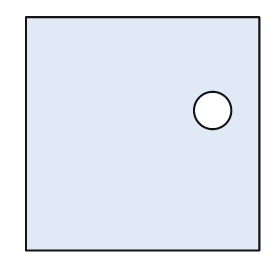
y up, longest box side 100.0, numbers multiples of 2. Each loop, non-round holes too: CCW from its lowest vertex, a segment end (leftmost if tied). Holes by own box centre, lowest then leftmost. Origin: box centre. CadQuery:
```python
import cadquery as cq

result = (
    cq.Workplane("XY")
    .moveTo(-50.0, -50.0)
    .lineTo(50.0, -50.0)
    .lineTo(50.0, 50.0)
    .lineTo(-50.0, 50.0)
    .close()
    .moveTo(30.0, 10.0)
    .circle(8.0)
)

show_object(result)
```